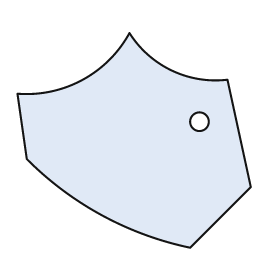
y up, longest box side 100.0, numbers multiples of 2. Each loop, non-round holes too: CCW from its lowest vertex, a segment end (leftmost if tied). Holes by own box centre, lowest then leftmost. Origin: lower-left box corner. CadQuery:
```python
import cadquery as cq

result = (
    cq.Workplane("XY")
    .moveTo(74.0, 0.0)
    .lineTo(100.0, 26.0)
    .lineTo(90.0, 72.0)
    .threePointArc((66.0, 76.0), (48.0, 92.0))
    .threePointArc((28.0, 72.0), (0.0, 66.0))
    .lineTo(4.0, 38.0)
    .threePointArc((36.0, 14.0), (74.0, 0.0))
    .close()
    .moveTo(78.0, 54.0)
    .circle(4.0)
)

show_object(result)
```